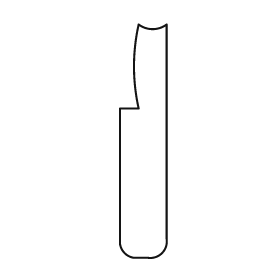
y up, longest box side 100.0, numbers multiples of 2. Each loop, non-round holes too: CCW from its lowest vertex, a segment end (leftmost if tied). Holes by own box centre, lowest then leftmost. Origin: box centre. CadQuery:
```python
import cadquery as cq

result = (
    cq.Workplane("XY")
    .moveTo(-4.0, -50.0)
    .lineTo(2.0, -50.0)
    .threePointArc((8.0, -48.0), (10.0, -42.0))
    .lineTo(10.0, 50.0)
    .threePointArc((4.0, 48.0), (-2.0, 50.0))
    .threePointArc((-4.0, 32.0), (-2.0, 14.0))
    .lineTo(-10.0, 14.0)
    .lineTo(-10.0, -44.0)
    .threePointArc((-8.0, -48.0), (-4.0, -50.0))
    .close()
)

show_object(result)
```